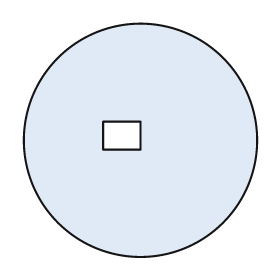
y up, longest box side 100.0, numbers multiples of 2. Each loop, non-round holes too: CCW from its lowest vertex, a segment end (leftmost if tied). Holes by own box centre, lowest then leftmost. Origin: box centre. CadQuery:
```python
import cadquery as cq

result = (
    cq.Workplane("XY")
    .moveTo(0.0, 0.0)
    .circle(50.0)
    .moveTo(-16.0, -4.0)
    .lineTo(0.0, -4.0)
    .lineTo(0.0, 8.0)
    .lineTo(-16.0, 8.0)
    .close()
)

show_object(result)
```